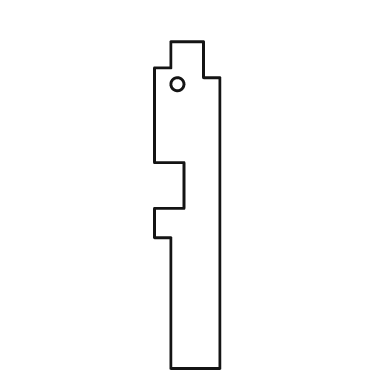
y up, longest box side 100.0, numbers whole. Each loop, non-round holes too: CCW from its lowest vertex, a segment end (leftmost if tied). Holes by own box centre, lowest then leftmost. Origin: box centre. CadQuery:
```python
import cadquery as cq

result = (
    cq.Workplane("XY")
    .moveTo(-5.0, -50.0)
    .lineTo(10.0, -50.0)
    .lineTo(10.0, 39.0)
    .lineTo(5.0, 39.0)
    .lineTo(5.0, 50.0)
    .lineTo(-5.0, 50.0)
    .lineTo(-5.0, 42.0)
    .lineTo(-10.0, 42.0)
    .lineTo(-10.0, 13.0)
    .lineTo(-1.0, 13.0)
    .lineTo(-1.0, -1.0)
    .lineTo(-10.0, -1.0)
    .lineTo(-10.0, -10.0)
    .lineTo(-5.0, -10.0)
    .close()
    .moveTo(-3.0, 37.0)
    .circle(2.0)
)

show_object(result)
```